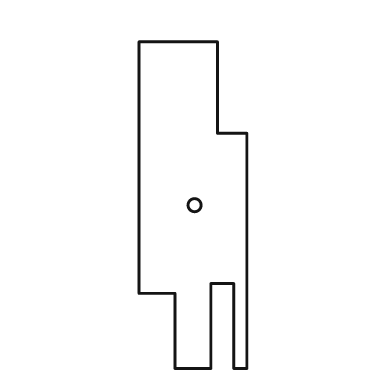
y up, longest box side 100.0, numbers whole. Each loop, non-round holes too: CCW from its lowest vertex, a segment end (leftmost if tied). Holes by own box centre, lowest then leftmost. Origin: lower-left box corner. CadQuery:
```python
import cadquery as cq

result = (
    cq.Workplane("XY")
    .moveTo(11.0, 0.0)
    .lineTo(22.0, 0.0)
    .lineTo(22.0, 26.0)
    .lineTo(29.0, 26.0)
    .lineTo(29.0, 0.0)
    .lineTo(33.0, 0.0)
    .lineTo(33.0, 72.0)
    .lineTo(24.0, 72.0)
    .lineTo(24.0, 100.0)
    .lineTo(0.0, 100.0)
    .lineTo(0.0, 23.0)
    .lineTo(11.0, 23.0)
    .close()
    .moveTo(17.0, 50.0)
    .circle(2.0)
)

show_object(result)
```